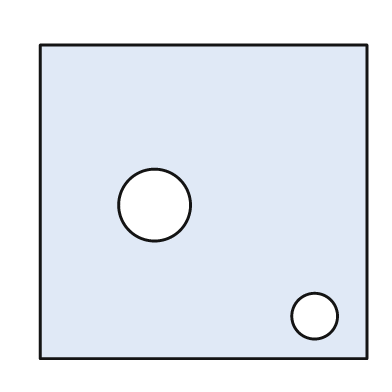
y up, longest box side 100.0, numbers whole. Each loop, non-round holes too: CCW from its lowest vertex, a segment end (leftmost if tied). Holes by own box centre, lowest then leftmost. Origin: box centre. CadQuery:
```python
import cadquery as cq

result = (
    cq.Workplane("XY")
    .moveTo(-50.0, -48.0)
    .lineTo(50.0, -48.0)
    .lineTo(50.0, 48.0)
    .lineTo(-50.0, 48.0)
    .close()
    .moveTo(34.0, -35.0)
    .circle(7.0)
    .moveTo(-15.0, -1.0)
    .circle(11.0)
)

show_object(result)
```